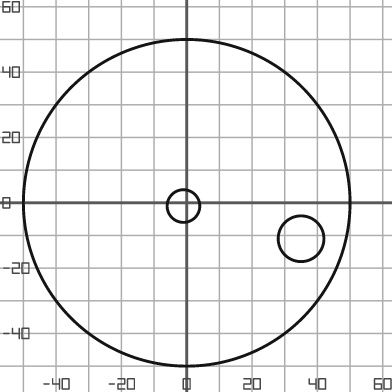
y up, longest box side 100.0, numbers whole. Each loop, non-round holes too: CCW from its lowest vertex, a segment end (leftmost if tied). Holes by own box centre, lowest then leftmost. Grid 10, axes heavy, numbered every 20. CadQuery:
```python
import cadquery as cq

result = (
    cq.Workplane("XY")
    .moveTo(0.0, 0.0)
    .circle(50.0)
    .moveTo(35.0, -11.0)
    .circle(7.0)
    .moveTo(-1.0, -1.0)
    .circle(5.0)
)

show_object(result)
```